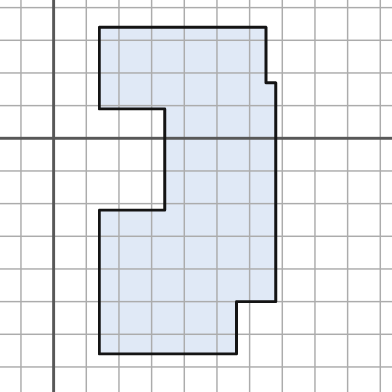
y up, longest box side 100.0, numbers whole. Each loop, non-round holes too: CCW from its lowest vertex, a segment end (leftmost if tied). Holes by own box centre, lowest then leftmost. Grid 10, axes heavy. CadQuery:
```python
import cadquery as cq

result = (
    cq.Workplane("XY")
    .moveTo(14.0, -66.0)
    .lineTo(56.0, -66.0)
    .lineTo(56.0, -50.0)
    .lineTo(68.0, -50.0)
    .lineTo(68.0, 17.0)
    .lineTo(65.0, 17.0)
    .lineTo(65.0, 34.0)
    .lineTo(14.0, 34.0)
    .lineTo(14.0, 9.0)
    .lineTo(34.0, 9.0)
    .lineTo(34.0, -22.0)
    .lineTo(14.0, -22.0)
    .close()
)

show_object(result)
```